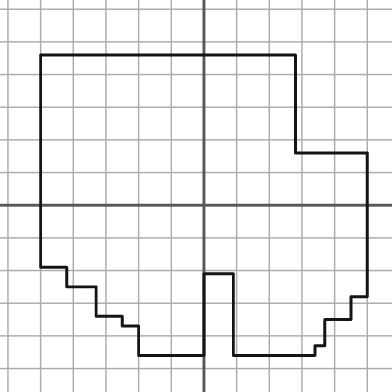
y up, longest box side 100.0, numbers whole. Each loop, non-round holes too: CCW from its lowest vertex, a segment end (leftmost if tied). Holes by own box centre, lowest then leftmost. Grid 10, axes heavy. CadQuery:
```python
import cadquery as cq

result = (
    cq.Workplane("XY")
    .moveTo(-20.0, -46.0)
    .lineTo(0.0, -46.0)
    .lineTo(0.0, -21.0)
    .lineTo(9.0, -21.0)
    .lineTo(9.0, -46.0)
    .lineTo(34.0, -46.0)
    .lineTo(34.0, -43.0)
    .lineTo(37.0, -43.0)
    .lineTo(37.0, -35.0)
    .lineTo(45.0, -35.0)
    .lineTo(45.0, -28.0)
    .lineTo(50.0, -28.0)
    .lineTo(50.0, 16.0)
    .lineTo(28.0, 16.0)
    .lineTo(28.0, 46.0)
    .lineTo(-50.0, 46.0)
    .lineTo(-50.0, -19.0)
    .lineTo(-42.0, -19.0)
    .lineTo(-42.0, -25.0)
    .lineTo(-33.0, -25.0)
    .lineTo(-33.0, -34.0)
    .lineTo(-25.0, -34.0)
    .lineTo(-25.0, -37.0)
    .lineTo(-20.0, -37.0)
    .close()
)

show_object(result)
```